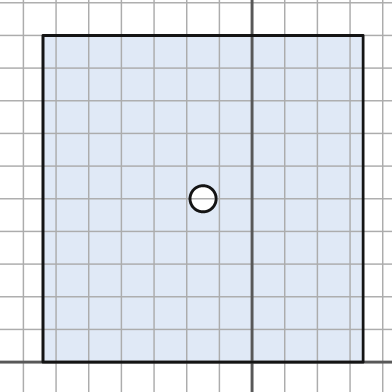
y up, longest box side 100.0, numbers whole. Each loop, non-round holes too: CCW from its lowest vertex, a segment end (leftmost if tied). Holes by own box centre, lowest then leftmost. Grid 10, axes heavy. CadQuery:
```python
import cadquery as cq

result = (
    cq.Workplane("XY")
    .moveTo(-64.0, 0.0)
    .lineTo(34.0, 0.0)
    .lineTo(34.0, 100.0)
    .lineTo(-64.0, 100.0)
    .close()
    .moveTo(-15.0, 50.0)
    .circle(4.0)
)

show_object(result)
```